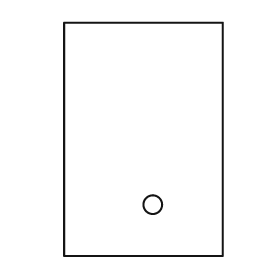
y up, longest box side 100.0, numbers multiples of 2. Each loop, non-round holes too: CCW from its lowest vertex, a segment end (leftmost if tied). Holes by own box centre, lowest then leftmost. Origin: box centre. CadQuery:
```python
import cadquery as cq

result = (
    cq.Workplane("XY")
    .moveTo(-34.0, -50.0)
    .lineTo(34.0, -50.0)
    .lineTo(34.0, 50.0)
    .lineTo(-34.0, 50.0)
    .close()
    .moveTo(4.0, -28.0)
    .circle(4.0)
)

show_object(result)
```